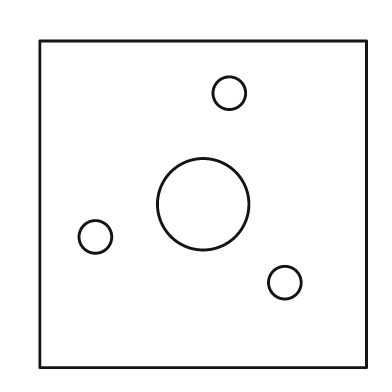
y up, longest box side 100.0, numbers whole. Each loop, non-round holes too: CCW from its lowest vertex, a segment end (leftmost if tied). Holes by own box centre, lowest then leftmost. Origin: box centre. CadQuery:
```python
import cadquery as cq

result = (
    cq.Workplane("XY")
    .moveTo(-50.0, -50.0)
    .lineTo(50.0, -50.0)
    .lineTo(50.0, 50.0)
    .lineTo(-50.0, 50.0)
    .close()
    .moveTo(25.0, -24.0)
    .circle(5.0)
    .moveTo(-33.0, -10.0)
    .circle(5.0)
    .moveTo(0.0, 0.0)
    .circle(14.0)
    .moveTo(8.0, 34.0)
    .circle(5.0)
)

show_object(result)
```